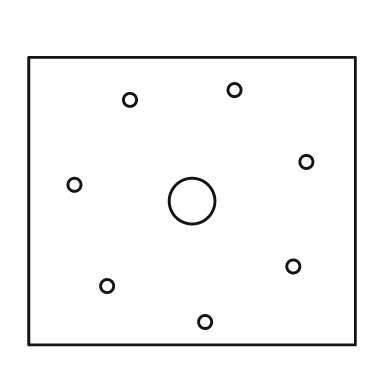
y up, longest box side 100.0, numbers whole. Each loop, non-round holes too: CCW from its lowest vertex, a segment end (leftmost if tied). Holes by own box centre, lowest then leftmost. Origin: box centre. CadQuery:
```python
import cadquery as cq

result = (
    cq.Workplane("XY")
    .moveTo(-50.0, -44.0)
    .lineTo(50.0, -44.0)
    .lineTo(50.0, 44.0)
    .lineTo(-50.0, 44.0)
    .close()
    .moveTo(4.0, -37.0)
    .circle(2.0)
    .moveTo(-26.0, -26.0)
    .circle(2.0)
    .moveTo(31.0, -20.0)
    .circle(2.0)
    .moveTo(0.0, 0.0)
    .circle(7.0)
    .moveTo(-36.0, 5.0)
    .circle(2.0)
    .moveTo(35.0, 12.0)
    .circle(2.0)
    .moveTo(-19.0, 31.0)
    .circle(2.0)
    .moveTo(13.0, 34.0)
    .circle(2.0)
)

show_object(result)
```